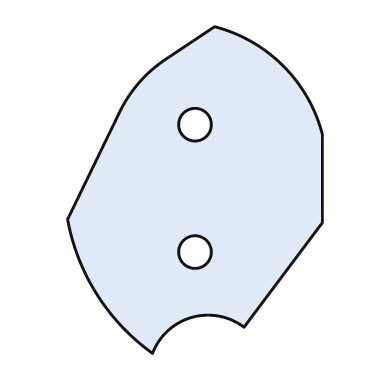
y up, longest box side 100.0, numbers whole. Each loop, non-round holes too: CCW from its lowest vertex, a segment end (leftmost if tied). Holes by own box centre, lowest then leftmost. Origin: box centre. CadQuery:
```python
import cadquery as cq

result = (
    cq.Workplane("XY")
    .moveTo(-13.0, -50.0)
    .threePointArc((-1.0, -39.0), (15.0, -42.0))
    .lineTo(39.0, -10.0)
    .lineTo(39.0, 17.0)
    .threePointArc((27.0, 38.0), (6.0, 50.0))
    .lineTo(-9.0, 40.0)
    .threePointArc((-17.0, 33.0), (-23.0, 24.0))
    .lineTo(-39.0, -9.0)
    .threePointArc((-30.0, -32.0), (-13.0, -50.0))
    .close()
    .moveTo(0.0, -19.0)
    .circle(5.0)
    .moveTo(0.0, 20.0)
    .circle(5.0)
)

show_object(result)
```